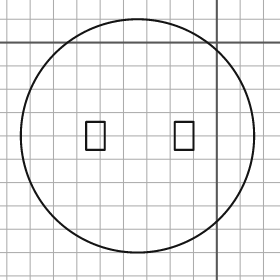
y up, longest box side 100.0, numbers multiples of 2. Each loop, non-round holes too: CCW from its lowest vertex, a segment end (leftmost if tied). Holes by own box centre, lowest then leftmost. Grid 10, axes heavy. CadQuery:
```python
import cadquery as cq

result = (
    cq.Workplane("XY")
    .moveTo(-34.0, -40.0)
    .circle(50.0)
    .moveTo(-56.0, -46.0)
    .lineTo(-48.0, -46.0)
    .lineTo(-48.0, -34.0)
    .lineTo(-56.0, -34.0)
    .close()
    .moveTo(-18.0, -46.0)
    .lineTo(-10.0, -46.0)
    .lineTo(-10.0, -34.0)
    .lineTo(-18.0, -34.0)
    .close()
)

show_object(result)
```